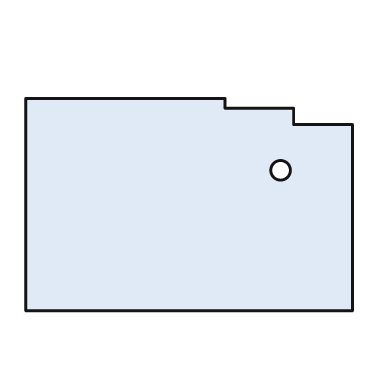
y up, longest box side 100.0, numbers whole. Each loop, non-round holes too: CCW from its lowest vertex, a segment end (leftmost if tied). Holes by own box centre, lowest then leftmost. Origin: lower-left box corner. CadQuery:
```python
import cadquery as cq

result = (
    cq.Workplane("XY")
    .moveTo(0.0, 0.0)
    .lineTo(100.0, 0.0)
    .lineTo(100.0, 57.0)
    .lineTo(82.0, 57.0)
    .lineTo(82.0, 62.0)
    .lineTo(61.0, 62.0)
    .lineTo(61.0, 65.0)
    .lineTo(0.0, 65.0)
    .close()
    .moveTo(78.0, 43.0)
    .circle(3.0)
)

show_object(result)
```